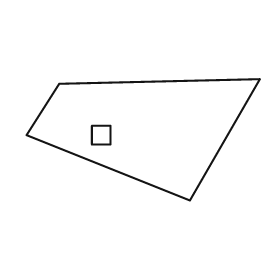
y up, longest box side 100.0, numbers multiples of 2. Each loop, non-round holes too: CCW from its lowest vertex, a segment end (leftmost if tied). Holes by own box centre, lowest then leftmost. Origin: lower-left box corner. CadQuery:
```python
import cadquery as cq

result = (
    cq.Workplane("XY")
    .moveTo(70.0, 0.0)
    .lineTo(100.0, 52.0)
    .lineTo(14.0, 50.0)
    .lineTo(0.0, 28.0)
    .close()
    .moveTo(28.0, 24.0)
    .lineTo(36.0, 24.0)
    .lineTo(36.0, 32.0)
    .lineTo(28.0, 32.0)
    .close()
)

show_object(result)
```